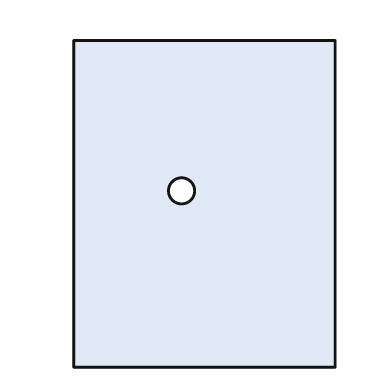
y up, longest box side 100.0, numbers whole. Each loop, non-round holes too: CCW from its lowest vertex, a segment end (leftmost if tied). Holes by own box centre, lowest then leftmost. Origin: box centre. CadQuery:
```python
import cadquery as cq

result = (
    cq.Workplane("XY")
    .moveTo(-40.0, -50.0)
    .lineTo(40.0, -50.0)
    .lineTo(40.0, 50.0)
    .lineTo(-40.0, 50.0)
    .close()
    .moveTo(-7.0, 4.0)
    .circle(4.0)
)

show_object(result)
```